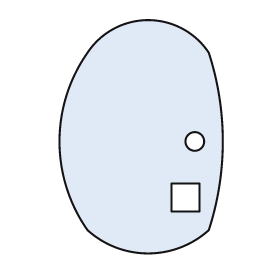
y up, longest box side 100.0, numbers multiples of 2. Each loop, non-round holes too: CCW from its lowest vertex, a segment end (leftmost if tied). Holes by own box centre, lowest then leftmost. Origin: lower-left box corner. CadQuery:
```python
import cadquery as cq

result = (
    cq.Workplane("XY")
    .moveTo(12.0, 10.0)
    .threePointArc((38.0, 0.0), (64.0, 10.0))
    .threePointArc((70.0, 48.0), (64.0, 86.0))
    .threePointArc((38.0, 100.0), (12.0, 86.0))
    .threePointArc((0.0, 48.0), (12.0, 10.0))
    .close()
    .moveTo(48.0, 18.0)
    .lineTo(60.0, 18.0)
    .lineTo(60.0, 30.0)
    .lineTo(48.0, 30.0)
    .close()
    .moveTo(58.0, 48.0)
    .circle(4.0)
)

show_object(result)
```